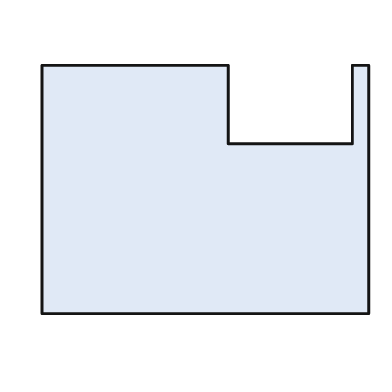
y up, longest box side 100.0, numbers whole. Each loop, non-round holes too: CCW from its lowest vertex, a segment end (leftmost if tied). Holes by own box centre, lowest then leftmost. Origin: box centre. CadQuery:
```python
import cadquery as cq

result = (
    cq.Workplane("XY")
    .moveTo(-50.0, -38.0)
    .lineTo(50.0, -38.0)
    .lineTo(50.0, 38.0)
    .lineTo(45.0, 38.0)
    .lineTo(45.0, 14.0)
    .lineTo(7.0, 14.0)
    .lineTo(7.0, 38.0)
    .lineTo(-50.0, 38.0)
    .close()
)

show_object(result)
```